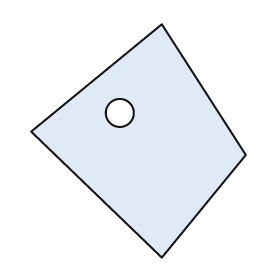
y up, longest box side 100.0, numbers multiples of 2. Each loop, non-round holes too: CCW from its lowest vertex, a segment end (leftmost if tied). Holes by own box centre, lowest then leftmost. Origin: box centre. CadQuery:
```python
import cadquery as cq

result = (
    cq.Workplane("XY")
    .moveTo(10.0, -50.0)
    .lineTo(46.0, -6.0)
    .lineTo(10.0, 50.0)
    .lineTo(-46.0, 4.0)
    .close()
    .moveTo(-8.0, 12.0)
    .circle(6.0)
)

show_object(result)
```